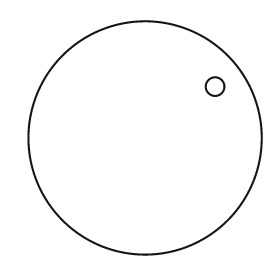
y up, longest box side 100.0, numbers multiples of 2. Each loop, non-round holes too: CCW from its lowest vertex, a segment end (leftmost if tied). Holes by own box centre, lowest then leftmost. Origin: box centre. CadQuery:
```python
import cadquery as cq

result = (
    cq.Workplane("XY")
    .moveTo(0.0, 0.0)
    .circle(50.0)
    .moveTo(30.0, 22.0)
    .circle(4.0)
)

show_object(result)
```